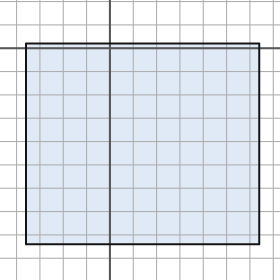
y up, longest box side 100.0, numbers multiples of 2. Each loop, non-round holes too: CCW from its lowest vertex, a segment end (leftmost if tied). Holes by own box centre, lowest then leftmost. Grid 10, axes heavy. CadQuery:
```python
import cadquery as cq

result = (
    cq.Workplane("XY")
    .moveTo(-36.0, -84.0)
    .lineTo(64.0, -84.0)
    .lineTo(64.0, 2.0)
    .lineTo(-36.0, 2.0)
    .close()
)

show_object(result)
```